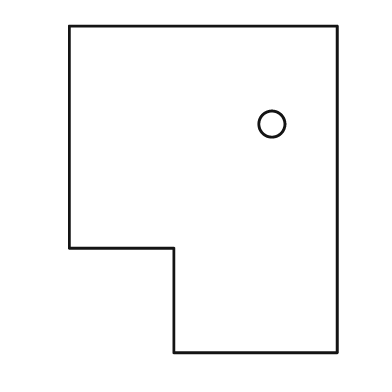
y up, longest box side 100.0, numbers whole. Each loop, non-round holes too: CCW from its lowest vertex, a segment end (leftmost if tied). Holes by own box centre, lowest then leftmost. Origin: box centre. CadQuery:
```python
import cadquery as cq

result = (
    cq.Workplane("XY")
    .moveTo(-9.0, -50.0)
    .lineTo(41.0, -50.0)
    .lineTo(41.0, 50.0)
    .lineTo(-41.0, 50.0)
    .lineTo(-41.0, -18.0)
    .lineTo(-9.0, -18.0)
    .close()
    .moveTo(21.0, 20.0)
    .circle(4.0)
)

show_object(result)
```